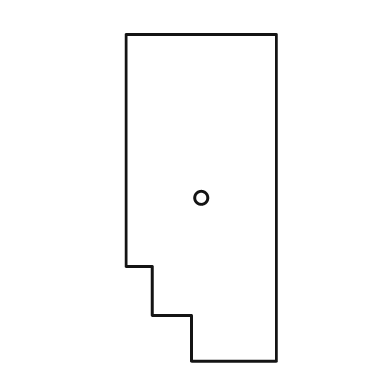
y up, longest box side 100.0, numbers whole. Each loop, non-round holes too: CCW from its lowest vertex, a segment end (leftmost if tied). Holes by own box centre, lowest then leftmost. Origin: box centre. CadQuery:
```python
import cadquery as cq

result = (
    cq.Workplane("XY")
    .moveTo(-3.0, -50.0)
    .lineTo(23.0, -50.0)
    .lineTo(23.0, 50.0)
    .lineTo(-23.0, 50.0)
    .lineTo(-23.0, -21.0)
    .lineTo(-15.0, -21.0)
    .lineTo(-15.0, -36.0)
    .lineTo(-3.0, -36.0)
    .close()
    .moveTo(0.0, 0.0)
    .circle(2.0)
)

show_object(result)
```